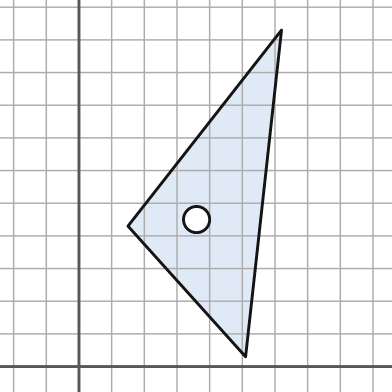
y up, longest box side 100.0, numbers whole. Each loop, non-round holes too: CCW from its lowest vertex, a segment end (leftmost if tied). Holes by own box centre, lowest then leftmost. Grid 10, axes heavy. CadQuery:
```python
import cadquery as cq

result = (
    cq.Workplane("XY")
    .moveTo(51.0, 3.0)
    .lineTo(62.0, 103.0)
    .lineTo(15.0, 43.0)
    .close()
    .moveTo(36.0, 45.0)
    .circle(4.0)
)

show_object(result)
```